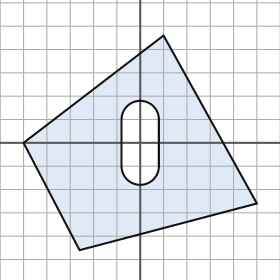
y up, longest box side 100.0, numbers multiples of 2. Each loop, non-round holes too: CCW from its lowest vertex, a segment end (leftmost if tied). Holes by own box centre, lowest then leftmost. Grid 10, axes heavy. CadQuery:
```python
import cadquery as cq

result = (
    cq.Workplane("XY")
    .moveTo(-26.0, -46.0)
    .lineTo(50.0, -26.0)
    .lineTo(10.0, 46.0)
    .lineTo(-50.0, 0.0)
    .close()
    .moveTo(-8.0, -10.0)
    .threePointArc((0.0, -18.0), (8.0, -10.0))
    .lineTo(8.0, 10.0)
    .threePointArc((0.0, 18.0), (-8.0, 10.0))
    .close()
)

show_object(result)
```